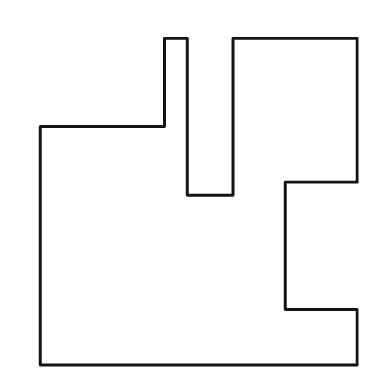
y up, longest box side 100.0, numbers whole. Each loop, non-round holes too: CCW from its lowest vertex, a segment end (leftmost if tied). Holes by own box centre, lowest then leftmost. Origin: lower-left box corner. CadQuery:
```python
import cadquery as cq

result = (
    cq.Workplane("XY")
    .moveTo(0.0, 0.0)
    .lineTo(97.0, 0.0)
    .lineTo(97.0, 17.0)
    .lineTo(75.0, 17.0)
    .lineTo(75.0, 56.0)
    .lineTo(97.0, 56.0)
    .lineTo(97.0, 100.0)
    .lineTo(59.0, 100.0)
    .lineTo(59.0, 52.0)
    .lineTo(45.0, 52.0)
    .lineTo(45.0, 100.0)
    .lineTo(38.0, 100.0)
    .lineTo(38.0, 73.0)
    .lineTo(0.0, 73.0)
    .close()
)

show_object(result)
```